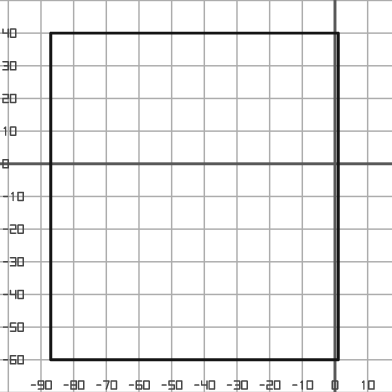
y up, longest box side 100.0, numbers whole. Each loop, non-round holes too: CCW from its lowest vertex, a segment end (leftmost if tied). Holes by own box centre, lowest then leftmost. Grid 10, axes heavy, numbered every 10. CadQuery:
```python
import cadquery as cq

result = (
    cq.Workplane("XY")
    .moveTo(-87.0, -60.0)
    .lineTo(1.0, -60.0)
    .lineTo(1.0, 40.0)
    .lineTo(-87.0, 40.0)
    .close()
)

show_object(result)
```